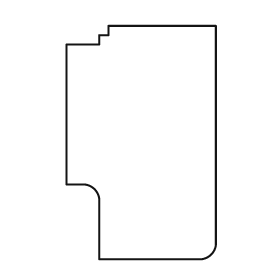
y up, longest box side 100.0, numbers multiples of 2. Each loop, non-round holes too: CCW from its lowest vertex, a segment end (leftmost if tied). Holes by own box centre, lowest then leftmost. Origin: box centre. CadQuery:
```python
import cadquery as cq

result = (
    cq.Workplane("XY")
    .moveTo(-18.0, -50.0)
    .lineTo(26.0, -50.0)
    .threePointArc((30.0, -48.0), (32.0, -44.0))
    .lineTo(32.0, 50.0)
    .lineTo(-14.0, 50.0)
    .lineTo(-14.0, 46.0)
    .lineTo(-18.0, 46.0)
    .lineTo(-18.0, 42.0)
    .lineTo(-32.0, 42.0)
    .lineTo(-32.0, -18.0)
    .lineTo(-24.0, -18.0)
    .threePointArc((-20.0, -20.0), (-18.0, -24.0))
    .close()
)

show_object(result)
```